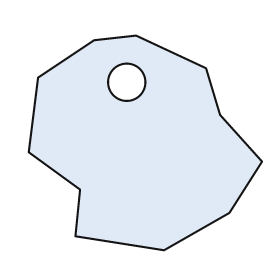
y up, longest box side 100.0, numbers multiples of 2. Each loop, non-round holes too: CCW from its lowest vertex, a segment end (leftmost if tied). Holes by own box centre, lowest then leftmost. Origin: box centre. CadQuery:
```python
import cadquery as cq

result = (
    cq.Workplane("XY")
    .moveTo(8.0, -46.0)
    .lineTo(36.0, -30.0)
    .lineTo(50.0, -8.0)
    .lineTo(32.0, 12.0)
    .lineTo(26.0, 32.0)
    .lineTo(-4.0, 46.0)
    .lineTo(-22.0, 44.0)
    .lineTo(-46.0, 28.0)
    .lineTo(-50.0, -4.0)
    .lineTo(-28.0, -20.0)
    .lineTo(-30.0, -40.0)
    .close()
    .moveTo(-8.0, 26.0)
    .circle(8.0)
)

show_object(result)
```